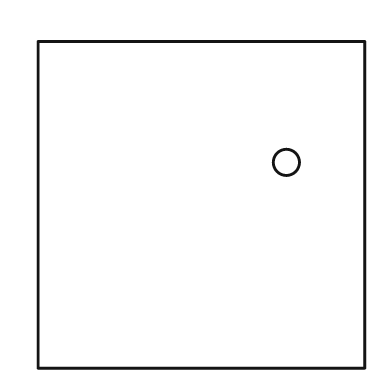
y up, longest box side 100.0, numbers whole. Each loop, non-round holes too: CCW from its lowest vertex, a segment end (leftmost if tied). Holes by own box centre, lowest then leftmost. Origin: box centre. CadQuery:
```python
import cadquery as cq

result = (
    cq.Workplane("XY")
    .moveTo(-50.0, -50.0)
    .lineTo(50.0, -50.0)
    .lineTo(50.0, 50.0)
    .lineTo(-50.0, 50.0)
    .close()
    .moveTo(26.0, 13.0)
    .circle(4.0)
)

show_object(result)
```